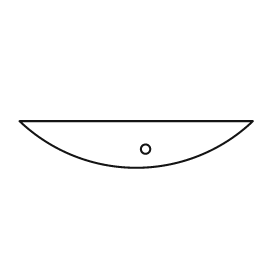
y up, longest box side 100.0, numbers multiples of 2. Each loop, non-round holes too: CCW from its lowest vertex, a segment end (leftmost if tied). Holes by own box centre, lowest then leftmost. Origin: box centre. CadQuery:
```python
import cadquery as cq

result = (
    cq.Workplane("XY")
    .moveTo(-50.0, 10.0)
    .threePointArc((0.0, -10.0), (50.0, 10.0))
    .close()
    .moveTo(4.0, -2.0)
    .circle(2.0)
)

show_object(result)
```